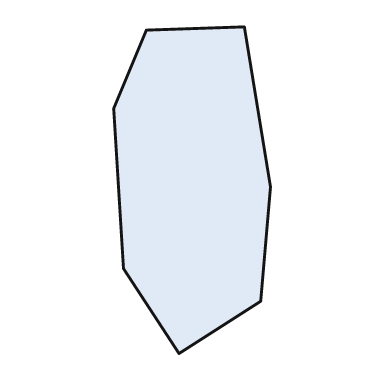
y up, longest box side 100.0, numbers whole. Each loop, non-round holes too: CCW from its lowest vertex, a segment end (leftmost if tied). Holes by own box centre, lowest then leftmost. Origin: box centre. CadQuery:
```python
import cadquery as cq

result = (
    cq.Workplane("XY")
    .moveTo(-4.0, -50.0)
    .lineTo(21.0, -34.0)
    .lineTo(24.0, 1.0)
    .lineTo(16.0, 50.0)
    .lineTo(-14.0, 49.0)
    .lineTo(-24.0, 25.0)
    .lineTo(-21.0, -24.0)
    .close()
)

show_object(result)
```